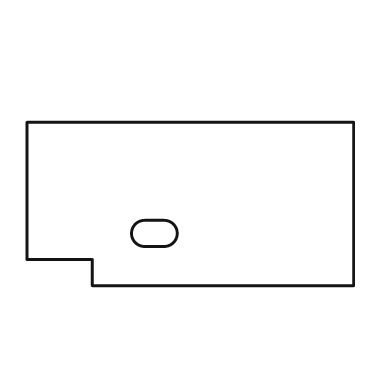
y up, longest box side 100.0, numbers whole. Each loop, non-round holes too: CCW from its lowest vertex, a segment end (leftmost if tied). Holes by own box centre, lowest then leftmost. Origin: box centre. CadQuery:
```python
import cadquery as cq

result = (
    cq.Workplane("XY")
    .moveTo(-30.0, -25.0)
    .lineTo(50.0, -25.0)
    .lineTo(50.0, 25.0)
    .lineTo(-50.0, 25.0)
    .lineTo(-50.0, -17.0)
    .lineTo(-30.0, -17.0)
    .close()
    .moveTo(-14.0, -13.0)
    .lineTo(-8.0, -13.0)
    .threePointArc((-4.0, -9.0), (-8.0, -5.0))
    .lineTo(-14.0, -5.0)
    .threePointArc((-18.0, -9.0), (-14.0, -13.0))
    .close()
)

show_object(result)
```